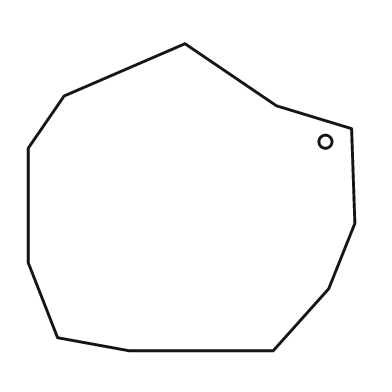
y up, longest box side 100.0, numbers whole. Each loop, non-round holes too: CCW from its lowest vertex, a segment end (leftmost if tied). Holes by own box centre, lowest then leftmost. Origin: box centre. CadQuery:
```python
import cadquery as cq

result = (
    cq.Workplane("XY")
    .moveTo(-19.0, -47.0)
    .lineTo(25.0, -47.0)
    .lineTo(42.0, -28.0)
    .lineTo(50.0, -8.0)
    .lineTo(49.0, 21.0)
    .lineTo(26.0, 28.0)
    .lineTo(-2.0, 47.0)
    .lineTo(-39.0, 31.0)
    .lineTo(-50.0, 15.0)
    .lineTo(-50.0, -20.0)
    .lineTo(-41.0, -43.0)
    .close()
    .moveTo(41.0, 17.0)
    .circle(2.0)
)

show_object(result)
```